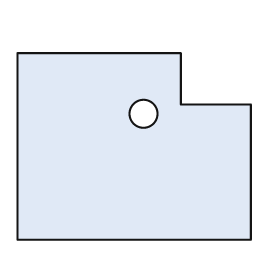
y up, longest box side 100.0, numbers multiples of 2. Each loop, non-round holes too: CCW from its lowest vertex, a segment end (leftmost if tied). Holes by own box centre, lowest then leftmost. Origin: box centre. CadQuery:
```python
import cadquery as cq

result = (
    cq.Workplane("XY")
    .moveTo(-50.0, -40.0)
    .lineTo(50.0, -40.0)
    .lineTo(50.0, 18.0)
    .lineTo(20.0, 18.0)
    .lineTo(20.0, 40.0)
    .lineTo(-50.0, 40.0)
    .close()
    .moveTo(4.0, 14.0)
    .circle(6.0)
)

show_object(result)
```